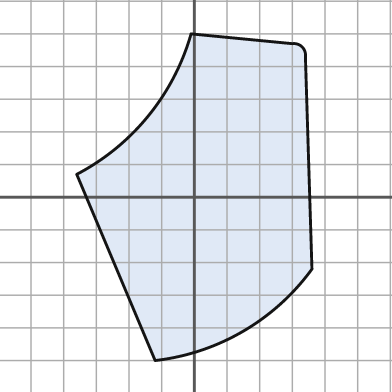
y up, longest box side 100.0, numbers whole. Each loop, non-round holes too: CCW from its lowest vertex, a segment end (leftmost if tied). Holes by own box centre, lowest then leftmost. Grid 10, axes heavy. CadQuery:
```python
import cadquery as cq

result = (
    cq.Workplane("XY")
    .moveTo(-12.0, -50.0)
    .threePointArc((15.0, -41.0), (36.0, -22.0))
    .lineTo(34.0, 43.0)
    .threePointArc((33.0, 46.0), (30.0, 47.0))
    .lineTo(-1.0, 50.0)
    .threePointArc((-14.0, 25.0), (-36.0, 7.0))
    .close()
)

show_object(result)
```